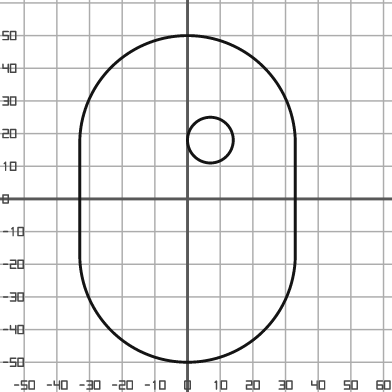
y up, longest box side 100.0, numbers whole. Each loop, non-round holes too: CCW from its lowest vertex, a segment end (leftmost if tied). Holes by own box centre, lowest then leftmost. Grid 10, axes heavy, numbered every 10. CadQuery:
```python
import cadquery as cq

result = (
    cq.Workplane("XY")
    .moveTo(-33.0, -17.0)
    .threePointArc((0.0, -50.0), (33.0, -17.0))
    .lineTo(33.0, 17.0)
    .threePointArc((0.0, 50.0), (-33.0, 17.0))
    .close()
    .moveTo(7.0, 18.0)
    .circle(7.0)
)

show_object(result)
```